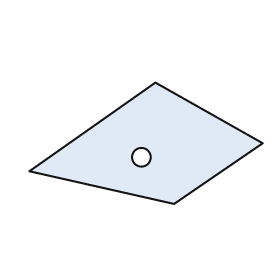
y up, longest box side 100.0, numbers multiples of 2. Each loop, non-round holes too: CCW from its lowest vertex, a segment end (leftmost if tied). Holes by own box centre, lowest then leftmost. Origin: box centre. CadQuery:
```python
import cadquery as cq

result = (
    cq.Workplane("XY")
    .moveTo(12.0, -26.0)
    .lineTo(50.0, 0.0)
    .lineTo(4.0, 26.0)
    .lineTo(-50.0, -12.0)
    .close()
    .moveTo(-2.0, -6.0)
    .circle(4.0)
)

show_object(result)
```